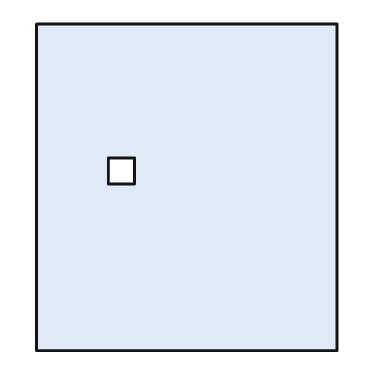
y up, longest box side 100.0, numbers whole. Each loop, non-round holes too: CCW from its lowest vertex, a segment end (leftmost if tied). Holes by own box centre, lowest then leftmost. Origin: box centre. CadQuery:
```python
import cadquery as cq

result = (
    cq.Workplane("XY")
    .moveTo(-46.0, -50.0)
    .lineTo(46.0, -50.0)
    .lineTo(46.0, 50.0)
    .lineTo(-46.0, 50.0)
    .close()
    .moveTo(-24.0, 1.0)
    .lineTo(-16.0, 1.0)
    .lineTo(-16.0, 9.0)
    .lineTo(-24.0, 9.0)
    .close()
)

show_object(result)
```